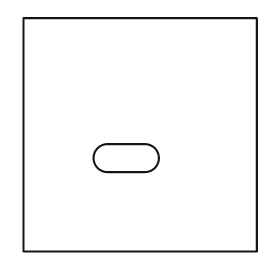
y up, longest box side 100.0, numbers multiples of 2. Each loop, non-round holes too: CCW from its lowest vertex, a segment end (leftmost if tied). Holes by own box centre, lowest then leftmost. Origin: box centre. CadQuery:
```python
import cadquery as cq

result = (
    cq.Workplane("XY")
    .moveTo(-50.0, -50.0)
    .lineTo(50.0, -50.0)
    .lineTo(50.0, 50.0)
    .lineTo(-50.0, 50.0)
    .close()
    .moveTo(-14.0, -16.0)
    .lineTo(2.0, -16.0)
    .threePointArc((8.0, -10.0), (2.0, -4.0))
    .lineTo(-14.0, -4.0)
    .threePointArc((-20.0, -10.0), (-14.0, -16.0))
    .close()
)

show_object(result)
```